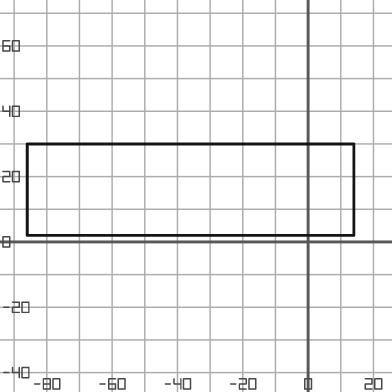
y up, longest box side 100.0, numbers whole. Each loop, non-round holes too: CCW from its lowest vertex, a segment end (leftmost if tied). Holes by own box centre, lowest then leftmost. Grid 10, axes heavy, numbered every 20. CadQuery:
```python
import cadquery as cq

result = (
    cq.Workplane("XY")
    .moveTo(-86.0, 2.0)
    .lineTo(14.0, 2.0)
    .lineTo(14.0, 30.0)
    .lineTo(-86.0, 30.0)
    .close()
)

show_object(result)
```